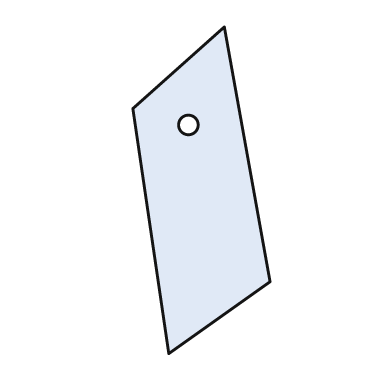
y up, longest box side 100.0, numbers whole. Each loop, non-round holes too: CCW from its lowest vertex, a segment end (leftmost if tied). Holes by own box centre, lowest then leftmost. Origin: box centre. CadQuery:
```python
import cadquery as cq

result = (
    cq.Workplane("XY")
    .moveTo(-10.0, -50.0)
    .lineTo(21.0, -28.0)
    .lineTo(7.0, 50.0)
    .lineTo(-21.0, 25.0)
    .close()
    .moveTo(-4.0, 20.0)
    .circle(3.0)
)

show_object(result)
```